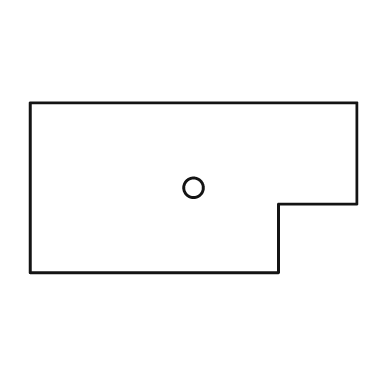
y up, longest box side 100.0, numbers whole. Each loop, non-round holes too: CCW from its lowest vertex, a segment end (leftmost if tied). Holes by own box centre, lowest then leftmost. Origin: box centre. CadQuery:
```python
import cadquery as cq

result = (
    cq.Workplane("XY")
    .moveTo(-50.0, -26.0)
    .lineTo(26.0, -26.0)
    .lineTo(26.0, -5.0)
    .lineTo(50.0, -5.0)
    .lineTo(50.0, 26.0)
    .lineTo(-50.0, 26.0)
    .close()
    .moveTo(0.0, 0.0)
    .circle(3.0)
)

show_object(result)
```